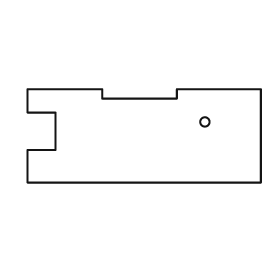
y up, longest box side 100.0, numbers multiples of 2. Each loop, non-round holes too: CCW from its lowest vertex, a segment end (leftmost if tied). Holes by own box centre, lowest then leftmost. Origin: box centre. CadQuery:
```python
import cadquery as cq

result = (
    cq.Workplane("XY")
    .moveTo(-50.0, -20.0)
    .lineTo(50.0, -20.0)
    .lineTo(50.0, 20.0)
    .lineTo(14.0, 20.0)
    .lineTo(14.0, 16.0)
    .lineTo(-18.0, 16.0)
    .lineTo(-18.0, 20.0)
    .lineTo(-50.0, 20.0)
    .lineTo(-50.0, 10.0)
    .lineTo(-38.0, 10.0)
    .lineTo(-38.0, -6.0)
    .lineTo(-50.0, -6.0)
    .close()
    .moveTo(26.0, 6.0)
    .circle(2.0)
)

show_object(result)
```